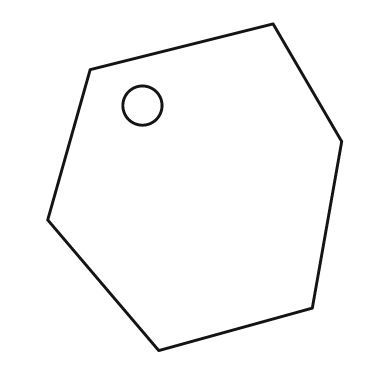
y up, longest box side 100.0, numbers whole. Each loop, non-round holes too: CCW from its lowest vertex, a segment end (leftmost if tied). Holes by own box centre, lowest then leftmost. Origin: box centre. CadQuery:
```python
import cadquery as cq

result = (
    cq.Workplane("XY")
    .moveTo(-11.0, -50.0)
    .lineTo(36.0, -37.0)
    .lineTo(45.0, 14.0)
    .lineTo(24.0, 50.0)
    .lineTo(-32.0, 36.0)
    .lineTo(-45.0, -10.0)
    .close()
    .moveTo(-16.0, 25.0)
    .circle(6.0)
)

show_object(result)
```